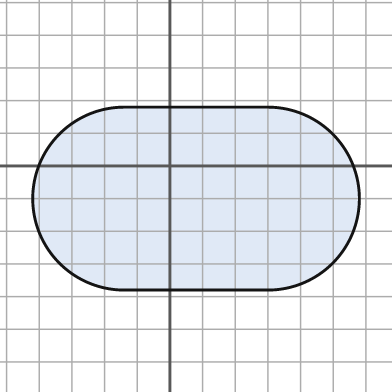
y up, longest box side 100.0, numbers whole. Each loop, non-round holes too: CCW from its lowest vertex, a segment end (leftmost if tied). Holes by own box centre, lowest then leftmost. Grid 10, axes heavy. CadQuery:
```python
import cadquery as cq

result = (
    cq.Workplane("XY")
    .moveTo(-14.0, -38.0)
    .lineTo(30.0, -38.0)
    .threePointArc((58.0, -10.0), (30.0, 18.0))
    .lineTo(-14.0, 18.0)
    .threePointArc((-42.0, -10.0), (-14.0, -38.0))
    .close()
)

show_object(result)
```